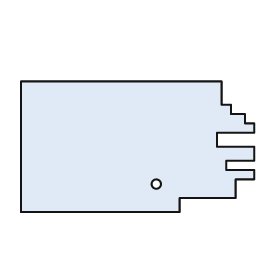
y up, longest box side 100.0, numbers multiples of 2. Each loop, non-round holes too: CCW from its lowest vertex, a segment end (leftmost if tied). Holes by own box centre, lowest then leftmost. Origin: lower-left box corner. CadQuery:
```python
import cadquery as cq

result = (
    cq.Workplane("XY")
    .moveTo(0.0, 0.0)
    .lineTo(68.0, 0.0)
    .lineTo(68.0, 6.0)
    .lineTo(92.0, 6.0)
    .lineTo(92.0, 14.0)
    .lineTo(100.0, 14.0)
    .lineTo(100.0, 18.0)
    .lineTo(88.0, 18.0)
    .lineTo(88.0, 22.0)
    .lineTo(100.0, 22.0)
    .lineTo(100.0, 28.0)
    .lineTo(84.0, 28.0)
    .lineTo(84.0, 34.0)
    .lineTo(100.0, 34.0)
    .lineTo(100.0, 38.0)
    .lineTo(96.0, 38.0)
    .lineTo(96.0, 42.0)
    .lineTo(90.0, 42.0)
    .lineTo(90.0, 46.0)
    .lineTo(86.0, 46.0)
    .lineTo(86.0, 56.0)
    .lineTo(0.0, 56.0)
    .close()
    .moveTo(58.0, 12.0)
    .circle(2.0)
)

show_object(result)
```